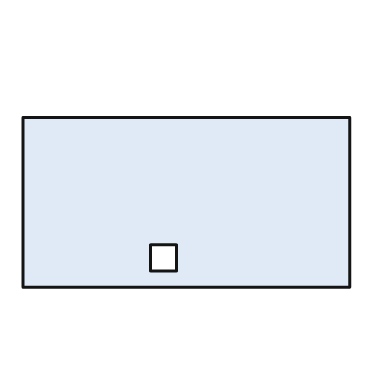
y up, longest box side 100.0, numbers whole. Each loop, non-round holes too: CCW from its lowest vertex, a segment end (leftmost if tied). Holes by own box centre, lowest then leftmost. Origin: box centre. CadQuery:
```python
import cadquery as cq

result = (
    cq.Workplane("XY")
    .moveTo(-50.0, -26.0)
    .lineTo(50.0, -26.0)
    .lineTo(50.0, 26.0)
    .lineTo(-50.0, 26.0)
    .close()
    .moveTo(-11.0, -21.0)
    .lineTo(-3.0, -21.0)
    .lineTo(-3.0, -13.0)
    .lineTo(-11.0, -13.0)
    .close()
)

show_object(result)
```